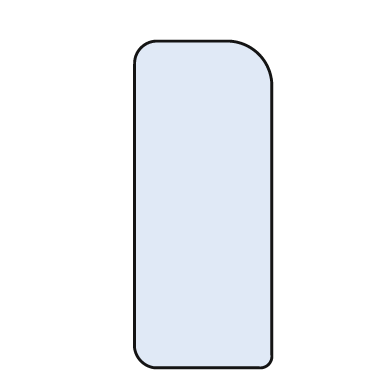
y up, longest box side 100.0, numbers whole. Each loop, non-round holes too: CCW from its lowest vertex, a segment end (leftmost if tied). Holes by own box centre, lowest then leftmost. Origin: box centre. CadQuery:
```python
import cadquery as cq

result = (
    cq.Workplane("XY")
    .moveTo(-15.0, -50.0)
    .lineTo(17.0, -50.0)
    .threePointArc((20.0, -49.0), (21.0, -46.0))
    .lineTo(21.0, 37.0)
    .threePointArc((17.0, 46.0), (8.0, 50.0))
    .lineTo(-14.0, 50.0)
    .threePointArc((-19.0, 48.0), (-21.0, 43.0))
    .lineTo(-21.0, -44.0)
    .threePointArc((-19.0, -48.0), (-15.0, -50.0))
    .close()
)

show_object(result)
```